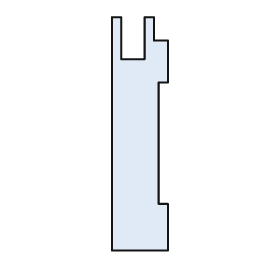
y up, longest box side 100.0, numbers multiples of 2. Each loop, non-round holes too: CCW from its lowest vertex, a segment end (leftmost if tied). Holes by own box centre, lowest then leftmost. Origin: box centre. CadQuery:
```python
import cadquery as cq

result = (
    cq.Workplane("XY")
    .moveTo(-12.0, -50.0)
    .lineTo(12.0, -50.0)
    .lineTo(12.0, -30.0)
    .lineTo(8.0, -30.0)
    .lineTo(8.0, 22.0)
    .lineTo(12.0, 22.0)
    .lineTo(12.0, 40.0)
    .lineTo(6.0, 40.0)
    .lineTo(6.0, 50.0)
    .lineTo(2.0, 50.0)
    .lineTo(2.0, 32.0)
    .lineTo(-8.0, 32.0)
    .lineTo(-8.0, 50.0)
    .lineTo(-12.0, 50.0)
    .close()
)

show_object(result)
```